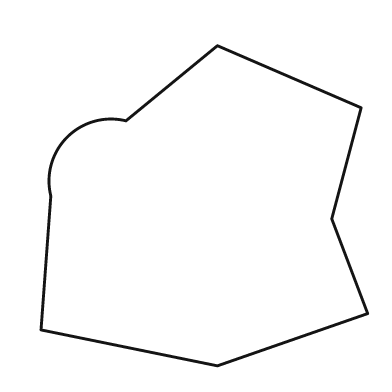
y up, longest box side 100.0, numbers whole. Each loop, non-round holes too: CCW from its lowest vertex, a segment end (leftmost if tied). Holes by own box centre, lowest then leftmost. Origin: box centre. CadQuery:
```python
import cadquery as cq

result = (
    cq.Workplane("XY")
    .moveTo(4.0, -49.0)
    .lineTo(50.0, -33.0)
    .lineTo(39.0, -4.0)
    .lineTo(48.0, 30.0)
    .lineTo(4.0, 49.0)
    .lineTo(-24.0, 26.0)
    .threePointArc((-42.0, 21.0), (-47.0, 3.0))
    .lineTo(-50.0, -38.0)
    .close()
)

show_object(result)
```